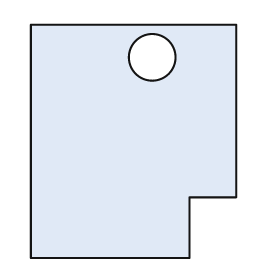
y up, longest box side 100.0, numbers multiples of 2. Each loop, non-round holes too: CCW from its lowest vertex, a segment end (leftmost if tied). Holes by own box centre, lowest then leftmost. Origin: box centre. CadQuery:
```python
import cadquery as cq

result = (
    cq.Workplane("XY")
    .moveTo(-44.0, -50.0)
    .lineTo(24.0, -50.0)
    .lineTo(24.0, -24.0)
    .lineTo(44.0, -24.0)
    .lineTo(44.0, 50.0)
    .lineTo(-44.0, 50.0)
    .close()
    .moveTo(8.0, 36.0)
    .circle(10.0)
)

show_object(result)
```